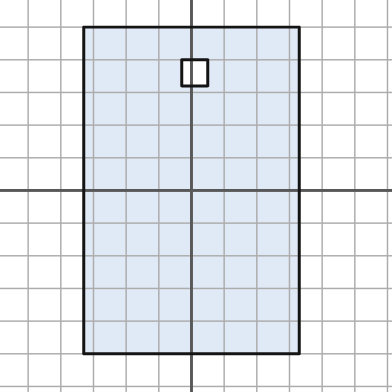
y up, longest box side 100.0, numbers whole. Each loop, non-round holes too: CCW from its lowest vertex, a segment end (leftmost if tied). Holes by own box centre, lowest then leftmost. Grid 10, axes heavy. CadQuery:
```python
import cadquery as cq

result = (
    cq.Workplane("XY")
    .moveTo(-33.0, -50.0)
    .lineTo(33.0, -50.0)
    .lineTo(33.0, 50.0)
    .lineTo(-33.0, 50.0)
    .close()
    .moveTo(-3.0, 32.0)
    .lineTo(5.0, 32.0)
    .lineTo(5.0, 40.0)
    .lineTo(-3.0, 40.0)
    .close()
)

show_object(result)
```